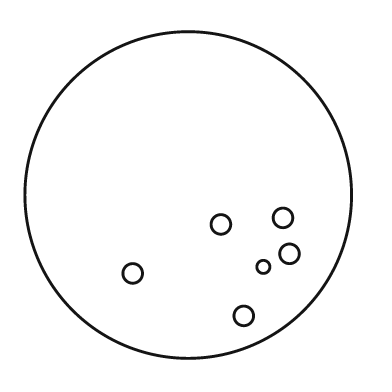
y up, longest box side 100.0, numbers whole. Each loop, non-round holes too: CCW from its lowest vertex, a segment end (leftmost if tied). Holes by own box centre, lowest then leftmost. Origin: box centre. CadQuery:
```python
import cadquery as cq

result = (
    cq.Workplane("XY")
    .moveTo(0.0, 0.0)
    .circle(50.0)
    .moveTo(17.0, -37.0)
    .circle(3.0)
    .moveTo(-17.0, -24.0)
    .circle(3.0)
    .moveTo(23.0, -22.0)
    .circle(2.0)
    .moveTo(31.0, -18.0)
    .circle(3.0)
    .moveTo(10.0, -9.0)
    .circle(3.0)
    .moveTo(29.0, -7.0)
    .circle(3.0)
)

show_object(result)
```